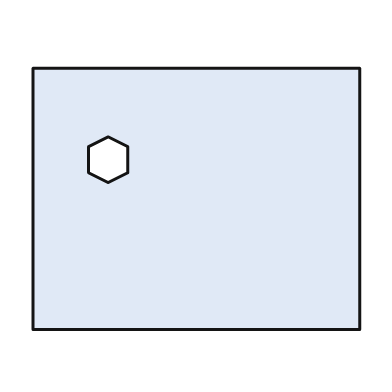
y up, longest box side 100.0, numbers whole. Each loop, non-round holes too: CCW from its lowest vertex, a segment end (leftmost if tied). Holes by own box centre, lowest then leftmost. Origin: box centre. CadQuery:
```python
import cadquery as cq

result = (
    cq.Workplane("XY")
    .moveTo(-50.0, -40.0)
    .lineTo(50.0, -40.0)
    .lineTo(50.0, 40.0)
    .lineTo(-50.0, 40.0)
    .close()
    .moveTo(-27.0, 5.0)
    .lineTo(-21.0, 8.0)
    .lineTo(-21.0, 16.0)
    .lineTo(-27.0, 19.0)
    .lineTo(-33.0, 16.0)
    .lineTo(-33.0, 8.0)
    .close()
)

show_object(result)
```